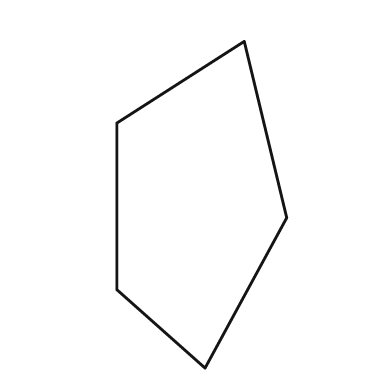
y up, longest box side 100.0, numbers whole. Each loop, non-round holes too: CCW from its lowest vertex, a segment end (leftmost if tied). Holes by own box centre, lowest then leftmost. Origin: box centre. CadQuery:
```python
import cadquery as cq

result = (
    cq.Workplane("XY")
    .moveTo(1.0, -50.0)
    .lineTo(26.0, -4.0)
    .lineTo(13.0, 50.0)
    .lineTo(-26.0, 25.0)
    .lineTo(-26.0, -26.0)
    .close()
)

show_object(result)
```